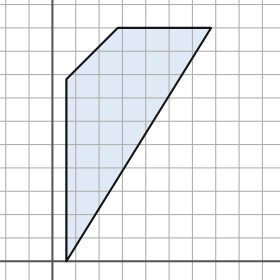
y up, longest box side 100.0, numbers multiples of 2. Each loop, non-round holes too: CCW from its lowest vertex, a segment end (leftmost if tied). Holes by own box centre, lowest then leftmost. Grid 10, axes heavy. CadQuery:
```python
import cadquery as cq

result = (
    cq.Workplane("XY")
    .moveTo(6.0, 0.0)
    .lineTo(68.0, 100.0)
    .lineTo(28.0, 100.0)
    .lineTo(6.0, 78.0)
    .close()
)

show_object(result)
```